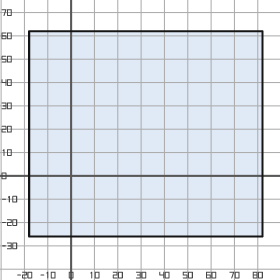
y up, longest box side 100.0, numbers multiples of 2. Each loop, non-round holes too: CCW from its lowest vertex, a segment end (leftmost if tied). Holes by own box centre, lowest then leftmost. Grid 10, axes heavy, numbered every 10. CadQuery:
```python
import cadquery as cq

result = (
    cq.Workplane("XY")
    .moveTo(-18.0, -26.0)
    .lineTo(82.0, -26.0)
    .lineTo(82.0, 62.0)
    .lineTo(-18.0, 62.0)
    .close()
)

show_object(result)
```